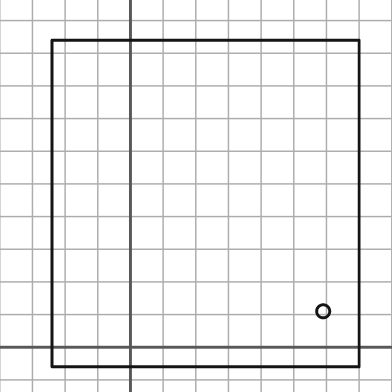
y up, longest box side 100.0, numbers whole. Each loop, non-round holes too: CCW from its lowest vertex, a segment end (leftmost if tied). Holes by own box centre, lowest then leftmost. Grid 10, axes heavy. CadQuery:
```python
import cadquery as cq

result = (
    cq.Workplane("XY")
    .moveTo(-24.0, -6.0)
    .lineTo(70.0, -6.0)
    .lineTo(70.0, 94.0)
    .lineTo(-24.0, 94.0)
    .close()
    .moveTo(59.0, 11.0)
    .circle(2.0)
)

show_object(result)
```